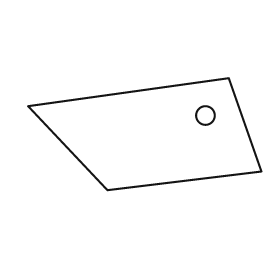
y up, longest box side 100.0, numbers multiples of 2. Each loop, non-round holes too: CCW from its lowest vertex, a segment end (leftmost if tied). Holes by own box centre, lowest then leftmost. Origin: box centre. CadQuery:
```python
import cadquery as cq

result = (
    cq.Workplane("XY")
    .moveTo(-16.0, -24.0)
    .lineTo(50.0, -16.0)
    .lineTo(36.0, 24.0)
    .lineTo(-50.0, 12.0)
    .close()
    .moveTo(26.0, 8.0)
    .circle(4.0)
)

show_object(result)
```